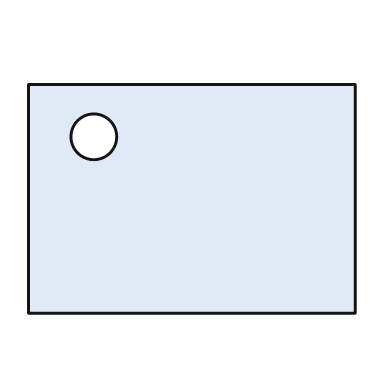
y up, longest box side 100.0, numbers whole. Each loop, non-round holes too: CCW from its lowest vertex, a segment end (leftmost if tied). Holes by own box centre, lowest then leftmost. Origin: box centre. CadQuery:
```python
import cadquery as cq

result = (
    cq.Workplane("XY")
    .moveTo(-50.0, -35.0)
    .lineTo(50.0, -35.0)
    .lineTo(50.0, 35.0)
    .lineTo(-50.0, 35.0)
    .close()
    .moveTo(-30.0, 19.0)
    .circle(7.0)
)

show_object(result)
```